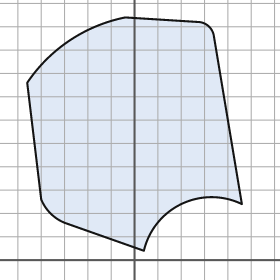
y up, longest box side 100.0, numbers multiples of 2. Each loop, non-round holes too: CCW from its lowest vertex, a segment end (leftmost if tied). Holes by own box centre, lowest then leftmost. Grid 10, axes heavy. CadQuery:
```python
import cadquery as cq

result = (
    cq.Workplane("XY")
    .moveTo(4.0, 4.0)
    .threePointArc((20.0, 24.0), (46.0, 24.0))
    .lineTo(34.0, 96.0)
    .threePointArc((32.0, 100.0), (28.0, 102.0))
    .lineTo(-4.0, 104.0)
    .threePointArc((-28.0, 94.0), (-46.0, 76.0))
    .lineTo(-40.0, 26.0)
    .threePointArc((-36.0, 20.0), (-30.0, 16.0))
    .close()
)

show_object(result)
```